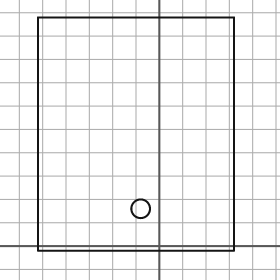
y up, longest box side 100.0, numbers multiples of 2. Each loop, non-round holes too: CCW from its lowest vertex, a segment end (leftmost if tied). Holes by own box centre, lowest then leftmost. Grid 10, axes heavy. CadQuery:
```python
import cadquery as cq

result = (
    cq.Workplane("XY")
    .moveTo(-52.0, -2.0)
    .lineTo(32.0, -2.0)
    .lineTo(32.0, 98.0)
    .lineTo(-52.0, 98.0)
    .close()
    .moveTo(-8.0, 16.0)
    .circle(4.0)
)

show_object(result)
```